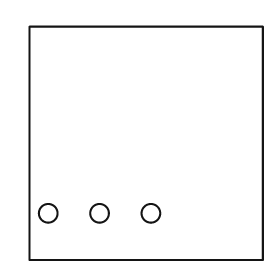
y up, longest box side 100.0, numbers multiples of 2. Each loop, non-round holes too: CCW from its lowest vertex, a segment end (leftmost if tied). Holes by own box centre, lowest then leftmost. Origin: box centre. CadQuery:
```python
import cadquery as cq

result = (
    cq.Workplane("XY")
    .moveTo(-50.0, -50.0)
    .lineTo(50.0, -50.0)
    .lineTo(50.0, 50.0)
    .lineTo(-50.0, 50.0)
    .close()
    .moveTo(-42.0, -30.0)
    .circle(4.0)
    .moveTo(-20.0, -30.0)
    .circle(4.0)
    .moveTo(2.0, -30.0)
    .circle(4.0)
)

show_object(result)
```